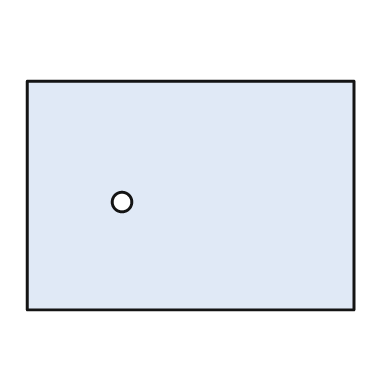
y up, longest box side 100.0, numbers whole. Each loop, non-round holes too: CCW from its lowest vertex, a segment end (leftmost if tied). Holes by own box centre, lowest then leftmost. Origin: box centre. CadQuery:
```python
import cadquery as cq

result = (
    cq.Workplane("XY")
    .moveTo(-50.0, -35.0)
    .lineTo(50.0, -35.0)
    .lineTo(50.0, 35.0)
    .lineTo(-50.0, 35.0)
    .close()
    .moveTo(-21.0, -2.0)
    .circle(3.0)
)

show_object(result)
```